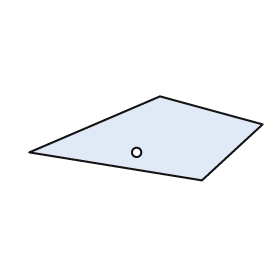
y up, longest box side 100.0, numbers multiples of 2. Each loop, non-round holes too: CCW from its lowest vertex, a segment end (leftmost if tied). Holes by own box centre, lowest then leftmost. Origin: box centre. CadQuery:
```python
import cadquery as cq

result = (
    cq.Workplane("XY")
    .moveTo(24.0, -18.0)
    .lineTo(50.0, 6.0)
    .lineTo(6.0, 18.0)
    .lineTo(-50.0, -6.0)
    .close()
    .moveTo(-4.0, -6.0)
    .circle(2.0)
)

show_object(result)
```